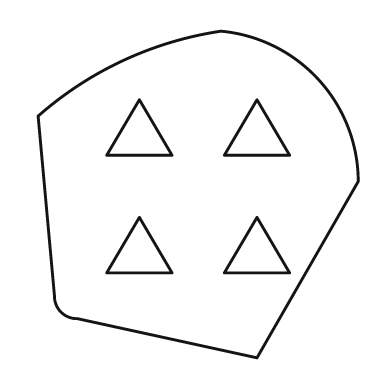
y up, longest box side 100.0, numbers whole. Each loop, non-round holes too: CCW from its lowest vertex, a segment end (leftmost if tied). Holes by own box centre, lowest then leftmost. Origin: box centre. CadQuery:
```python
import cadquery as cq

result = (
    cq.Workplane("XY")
    .moveTo(18.0, -50.0)
    .lineTo(49.0, 4.0)
    .threePointArc((37.0, 35.0), (7.0, 50.0))
    .threePointArc((-23.0, 41.0), (-49.0, 24.0))
    .lineTo(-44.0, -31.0)
    .threePointArc((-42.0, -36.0), (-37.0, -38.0))
    .close()
    .moveTo(-28.0, -24.0)
    .lineTo(-8.0, -24.0)
    .lineTo(-18.0, -7.0)
    .close()
    .moveTo(8.0, -24.0)
    .lineTo(28.0, -24.0)
    .lineTo(18.0, -7.0)
    .close()
    .moveTo(-28.0, 12.0)
    .lineTo(-8.0, 12.0)
    .lineTo(-18.0, 29.0)
    .close()
    .moveTo(8.0, 12.0)
    .lineTo(28.0, 12.0)
    .lineTo(18.0, 29.0)
    .close()
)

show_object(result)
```